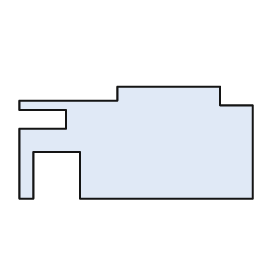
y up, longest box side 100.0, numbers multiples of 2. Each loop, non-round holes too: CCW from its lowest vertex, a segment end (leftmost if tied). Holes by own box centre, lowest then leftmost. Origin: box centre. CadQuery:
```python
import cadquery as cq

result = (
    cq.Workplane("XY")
    .moveTo(-50.0, -24.0)
    .lineTo(-44.0, -24.0)
    .lineTo(-44.0, -4.0)
    .lineTo(-24.0, -4.0)
    .lineTo(-24.0, -24.0)
    .lineTo(50.0, -24.0)
    .lineTo(50.0, 16.0)
    .lineTo(36.0, 16.0)
    .lineTo(36.0, 24.0)
    .lineTo(-8.0, 24.0)
    .lineTo(-8.0, 18.0)
    .lineTo(-50.0, 18.0)
    .lineTo(-50.0, 14.0)
    .lineTo(-30.0, 14.0)
    .lineTo(-30.0, 6.0)
    .lineTo(-50.0, 6.0)
    .close()
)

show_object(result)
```